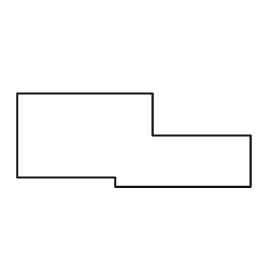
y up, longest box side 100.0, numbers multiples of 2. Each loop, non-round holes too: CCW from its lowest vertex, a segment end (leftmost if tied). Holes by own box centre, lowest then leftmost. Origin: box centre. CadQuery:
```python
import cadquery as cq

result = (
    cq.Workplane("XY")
    .moveTo(-8.0, -20.0)
    .lineTo(50.0, -20.0)
    .lineTo(50.0, 2.0)
    .lineTo(8.0, 2.0)
    .lineTo(8.0, 20.0)
    .lineTo(-50.0, 20.0)
    .lineTo(-50.0, -16.0)
    .lineTo(-8.0, -16.0)
    .close()
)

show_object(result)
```